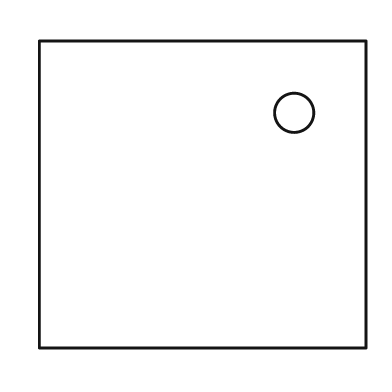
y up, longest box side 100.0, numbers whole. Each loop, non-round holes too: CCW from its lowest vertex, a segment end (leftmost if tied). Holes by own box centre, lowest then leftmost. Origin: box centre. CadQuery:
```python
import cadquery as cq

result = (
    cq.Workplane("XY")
    .moveTo(-50.0, -47.0)
    .lineTo(50.0, -47.0)
    .lineTo(50.0, 47.0)
    .lineTo(-50.0, 47.0)
    .close()
    .moveTo(28.0, 25.0)
    .circle(6.0)
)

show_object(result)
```